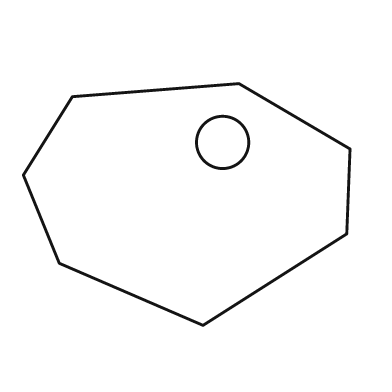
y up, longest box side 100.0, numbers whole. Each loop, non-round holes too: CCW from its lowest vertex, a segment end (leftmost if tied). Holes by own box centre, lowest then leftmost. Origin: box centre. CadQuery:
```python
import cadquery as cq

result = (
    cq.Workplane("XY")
    .moveTo(5.0, -37.0)
    .lineTo(49.0, -9.0)
    .lineTo(50.0, 17.0)
    .lineTo(16.0, 37.0)
    .lineTo(-35.0, 33.0)
    .lineTo(-50.0, 9.0)
    .lineTo(-39.0, -18.0)
    .close()
    .moveTo(11.0, 19.0)
    .circle(8.0)
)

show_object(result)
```